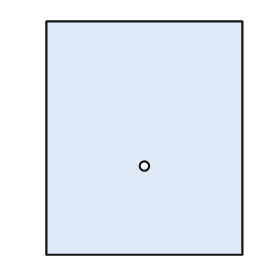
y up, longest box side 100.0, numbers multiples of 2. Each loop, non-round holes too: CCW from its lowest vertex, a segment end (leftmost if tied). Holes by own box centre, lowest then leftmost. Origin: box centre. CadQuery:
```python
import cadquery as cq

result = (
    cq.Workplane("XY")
    .moveTo(-42.0, -50.0)
    .lineTo(42.0, -50.0)
    .lineTo(42.0, 50.0)
    .lineTo(-42.0, 50.0)
    .close()
    .moveTo(0.0, -12.0)
    .circle(2.0)
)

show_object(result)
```